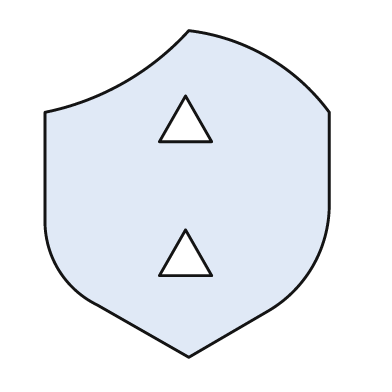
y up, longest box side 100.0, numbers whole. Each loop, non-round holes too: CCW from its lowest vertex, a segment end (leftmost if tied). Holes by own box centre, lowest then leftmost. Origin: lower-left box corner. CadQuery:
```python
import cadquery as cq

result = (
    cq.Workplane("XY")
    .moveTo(44.0, 0.0)
    .lineTo(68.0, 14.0)
    .threePointArc((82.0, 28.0), (87.0, 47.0))
    .lineTo(87.0, 75.0)
    .threePointArc((68.0, 92.0), (44.0, 100.0))
    .threePointArc((24.0, 84.0), (0.0, 75.0))
    .lineTo(0.0, 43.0)
    .threePointArc((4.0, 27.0), (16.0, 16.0))
    .close()
    .moveTo(35.0, 25.0)
    .lineTo(51.0, 25.0)
    .lineTo(43.0, 39.0)
    .close()
    .moveTo(35.0, 66.0)
    .lineTo(51.0, 66.0)
    .lineTo(43.0, 80.0)
    .close()
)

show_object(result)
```